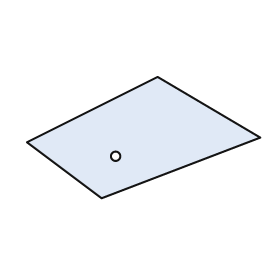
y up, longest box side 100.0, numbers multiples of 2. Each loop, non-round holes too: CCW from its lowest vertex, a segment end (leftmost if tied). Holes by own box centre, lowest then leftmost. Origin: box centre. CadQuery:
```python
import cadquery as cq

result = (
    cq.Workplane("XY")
    .moveTo(-18.0, -26.0)
    .lineTo(50.0, 0.0)
    .lineTo(6.0, 26.0)
    .lineTo(-50.0, -2.0)
    .close()
    .moveTo(-12.0, -8.0)
    .circle(2.0)
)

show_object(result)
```